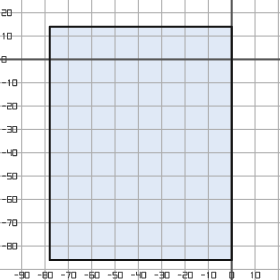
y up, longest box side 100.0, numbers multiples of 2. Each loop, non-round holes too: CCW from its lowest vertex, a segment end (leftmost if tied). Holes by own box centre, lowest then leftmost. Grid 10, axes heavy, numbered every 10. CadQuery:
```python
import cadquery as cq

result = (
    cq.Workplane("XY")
    .moveTo(-78.0, -86.0)
    .lineTo(0.0, -86.0)
    .lineTo(0.0, 14.0)
    .lineTo(-78.0, 14.0)
    .close()
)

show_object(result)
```